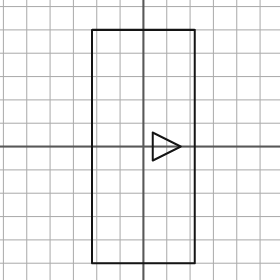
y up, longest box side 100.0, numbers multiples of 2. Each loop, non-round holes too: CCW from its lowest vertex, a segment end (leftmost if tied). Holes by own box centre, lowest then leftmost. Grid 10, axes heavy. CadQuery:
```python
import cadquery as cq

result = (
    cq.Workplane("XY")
    .moveTo(-22.0, -50.0)
    .lineTo(22.0, -50.0)
    .lineTo(22.0, 50.0)
    .lineTo(-22.0, 50.0)
    .close()
    .moveTo(4.0, -6.0)
    .lineTo(16.0, 0.0)
    .lineTo(4.0, 6.0)
    .close()
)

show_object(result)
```